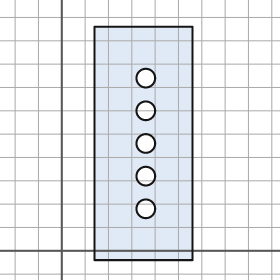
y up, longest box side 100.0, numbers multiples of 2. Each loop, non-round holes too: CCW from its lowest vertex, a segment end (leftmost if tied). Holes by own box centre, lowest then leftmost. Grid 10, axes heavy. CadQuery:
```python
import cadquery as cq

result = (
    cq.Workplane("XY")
    .moveTo(14.0, -4.0)
    .lineTo(56.0, -4.0)
    .lineTo(56.0, 96.0)
    .lineTo(14.0, 96.0)
    .close()
    .moveTo(36.0, 18.0)
    .circle(4.0)
    .moveTo(36.0, 32.0)
    .circle(4.0)
    .moveTo(36.0, 46.0)
    .circle(4.0)
    .moveTo(36.0, 60.0)
    .circle(4.0)
    .moveTo(36.0, 74.0)
    .circle(4.0)
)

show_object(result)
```